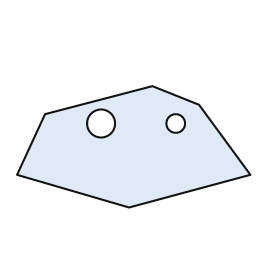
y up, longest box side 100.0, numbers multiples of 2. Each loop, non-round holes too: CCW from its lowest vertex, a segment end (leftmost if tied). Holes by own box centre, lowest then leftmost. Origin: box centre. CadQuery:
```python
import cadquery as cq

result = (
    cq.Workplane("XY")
    .moveTo(-2.0, -26.0)
    .lineTo(50.0, -12.0)
    .lineTo(28.0, 18.0)
    .lineTo(8.0, 26.0)
    .lineTo(-38.0, 14.0)
    .lineTo(-50.0, -12.0)
    .close()
    .moveTo(-14.0, 10.0)
    .circle(6.0)
    .moveTo(18.0, 10.0)
    .circle(4.0)
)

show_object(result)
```